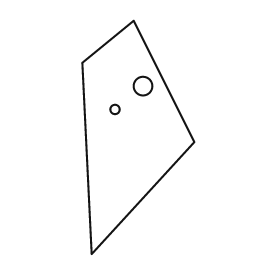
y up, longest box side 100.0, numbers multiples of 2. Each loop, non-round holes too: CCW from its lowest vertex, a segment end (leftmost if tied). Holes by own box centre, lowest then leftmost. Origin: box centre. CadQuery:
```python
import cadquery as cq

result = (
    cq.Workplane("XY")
    .moveTo(-20.0, -50.0)
    .lineTo(24.0, -2.0)
    .lineTo(-2.0, 50.0)
    .lineTo(-24.0, 32.0)
    .close()
    .moveTo(-10.0, 12.0)
    .circle(2.0)
    .moveTo(2.0, 22.0)
    .circle(4.0)
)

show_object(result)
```